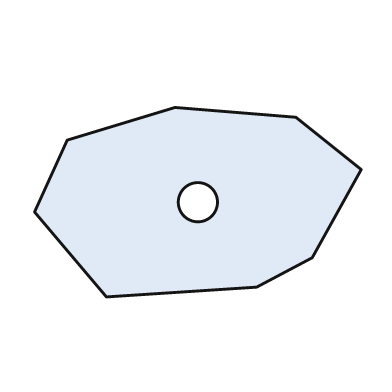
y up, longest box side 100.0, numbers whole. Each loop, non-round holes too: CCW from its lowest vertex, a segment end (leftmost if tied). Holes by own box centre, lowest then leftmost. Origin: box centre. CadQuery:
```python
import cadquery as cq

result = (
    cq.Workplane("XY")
    .moveTo(-28.0, -29.0)
    .lineTo(18.0, -26.0)
    .lineTo(35.0, -17.0)
    .lineTo(50.0, 10.0)
    .lineTo(30.0, 26.0)
    .lineTo(-7.0, 29.0)
    .lineTo(-40.0, 19.0)
    .lineTo(-50.0, -3.0)
    .close()
    .moveTo(0.0, 0.0)
    .circle(6.0)
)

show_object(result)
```